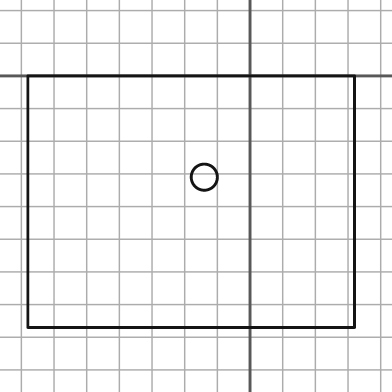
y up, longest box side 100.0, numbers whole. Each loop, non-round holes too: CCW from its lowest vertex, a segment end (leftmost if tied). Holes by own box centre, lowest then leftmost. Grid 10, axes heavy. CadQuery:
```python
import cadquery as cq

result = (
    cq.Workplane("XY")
    .moveTo(-68.0, -77.0)
    .lineTo(32.0, -77.0)
    .lineTo(32.0, 0.0)
    .lineTo(-68.0, 0.0)
    .close()
    .moveTo(-14.0, -31.0)
    .circle(4.0)
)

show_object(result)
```